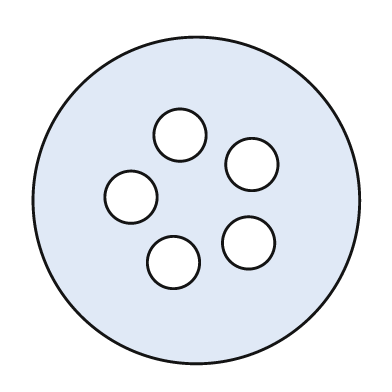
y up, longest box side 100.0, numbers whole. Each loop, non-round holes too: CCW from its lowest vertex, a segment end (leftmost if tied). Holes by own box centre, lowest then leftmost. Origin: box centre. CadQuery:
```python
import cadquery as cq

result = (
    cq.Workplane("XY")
    .moveTo(0.0, 0.0)
    .circle(50.0)
    .moveTo(-7.0, -19.0)
    .circle(8.0)
    .moveTo(16.0, -13.0)
    .circle(8.0)
    .moveTo(-20.0, 1.0)
    .circle(8.0)
    .moveTo(17.0, 11.0)
    .circle(8.0)
    .moveTo(-5.0, 20.0)
    .circle(8.0)
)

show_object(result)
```